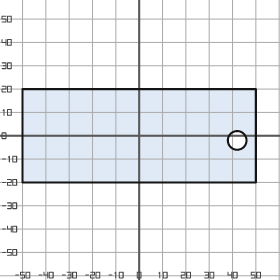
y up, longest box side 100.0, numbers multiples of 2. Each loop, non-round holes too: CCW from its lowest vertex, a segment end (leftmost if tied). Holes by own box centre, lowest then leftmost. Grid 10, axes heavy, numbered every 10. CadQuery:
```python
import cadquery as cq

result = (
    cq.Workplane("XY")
    .moveTo(-50.0, -20.0)
    .lineTo(50.0, -20.0)
    .lineTo(50.0, 20.0)
    .lineTo(-50.0, 20.0)
    .close()
    .moveTo(42.0, -2.0)
    .circle(4.0)
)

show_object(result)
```